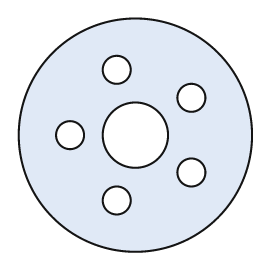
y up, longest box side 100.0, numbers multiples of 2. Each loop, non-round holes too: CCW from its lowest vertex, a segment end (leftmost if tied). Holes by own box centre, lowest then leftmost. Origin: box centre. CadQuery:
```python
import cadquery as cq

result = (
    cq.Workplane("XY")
    .moveTo(0.0, 0.0)
    .circle(50.0)
    .moveTo(-8.0, -28.0)
    .circle(6.0)
    .moveTo(24.0, -16.0)
    .circle(6.0)
    .moveTo(-28.0, 0.0)
    .circle(6.0)
    .moveTo(0.0, 0.0)
    .circle(14.0)
    .moveTo(24.0, 16.0)
    .circle(6.0)
    .moveTo(-8.0, 28.0)
    .circle(6.0)
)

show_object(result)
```